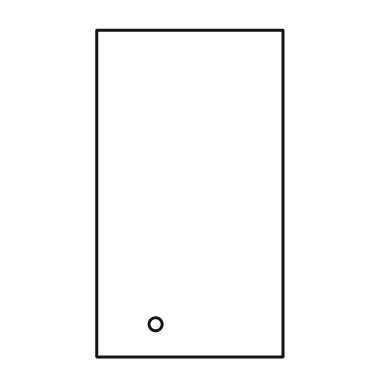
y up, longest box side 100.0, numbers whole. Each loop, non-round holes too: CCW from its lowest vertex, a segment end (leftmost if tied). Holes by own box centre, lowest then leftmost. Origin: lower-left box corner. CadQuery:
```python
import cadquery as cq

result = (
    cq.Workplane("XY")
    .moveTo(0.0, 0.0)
    .lineTo(57.0, 0.0)
    .lineTo(57.0, 100.0)
    .lineTo(0.0, 100.0)
    .close()
    .moveTo(18.0, 10.0)
    .circle(2.0)
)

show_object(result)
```